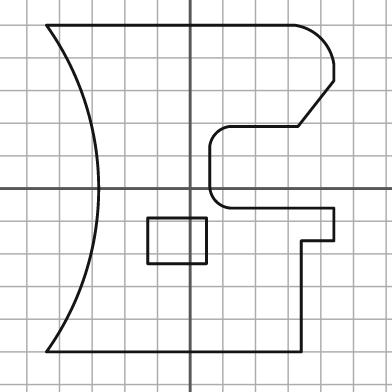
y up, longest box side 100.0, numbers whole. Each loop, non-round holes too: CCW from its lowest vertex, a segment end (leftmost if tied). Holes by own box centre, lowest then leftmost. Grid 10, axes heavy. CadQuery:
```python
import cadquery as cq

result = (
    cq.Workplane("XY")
    .moveTo(-44.0, -50.0)
    .lineTo(34.0, -50.0)
    .lineTo(34.0, -16.0)
    .lineTo(44.0, -16.0)
    .lineTo(44.0, -6.0)
    .lineTo(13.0, -6.0)
    .threePointArc((8.0, -4.0), (6.0, 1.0))
    .lineTo(6.0, 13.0)
    .threePointArc((8.0, 17.0), (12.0, 19.0))
    .lineTo(33.0, 19.0)
    .lineTo(44.0, 33.0)
    .lineTo(44.0, 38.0)
    .threePointArc((40.0, 46.0), (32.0, 50.0))
    .lineTo(-44.0, 50.0)
    .threePointArc((-28.0, 0.0), (-44.0, -50.0))
    .close()
    .moveTo(-13.0, -23.0)
    .lineTo(5.0, -23.0)
    .lineTo(5.0, -9.0)
    .lineTo(-13.0, -9.0)
    .close()
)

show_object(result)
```